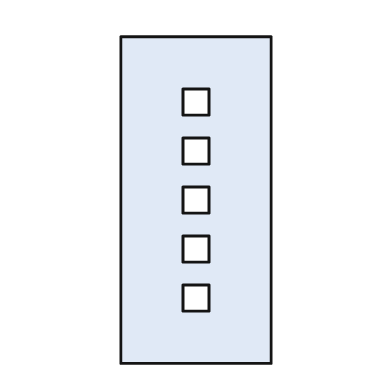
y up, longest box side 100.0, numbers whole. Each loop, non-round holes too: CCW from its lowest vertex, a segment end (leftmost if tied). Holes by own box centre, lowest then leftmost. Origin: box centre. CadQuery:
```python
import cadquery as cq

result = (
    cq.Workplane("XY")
    .moveTo(-23.0, -50.0)
    .lineTo(23.0, -50.0)
    .lineTo(23.0, 50.0)
    .lineTo(-23.0, 50.0)
    .close()
    .moveTo(-4.0, -34.0)
    .lineTo(4.0, -34.0)
    .lineTo(4.0, -26.0)
    .lineTo(-4.0, -26.0)
    .close()
    .moveTo(-4.0, -19.0)
    .lineTo(4.0, -19.0)
    .lineTo(4.0, -11.0)
    .lineTo(-4.0, -11.0)
    .close()
    .moveTo(-4.0, -4.0)
    .lineTo(4.0, -4.0)
    .lineTo(4.0, 4.0)
    .lineTo(-4.0, 4.0)
    .close()
    .moveTo(-4.0, 11.0)
    .lineTo(4.0, 11.0)
    .lineTo(4.0, 19.0)
    .lineTo(-4.0, 19.0)
    .close()
    .moveTo(-4.0, 26.0)
    .lineTo(4.0, 26.0)
    .lineTo(4.0, 34.0)
    .lineTo(-4.0, 34.0)
    .close()
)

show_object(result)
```